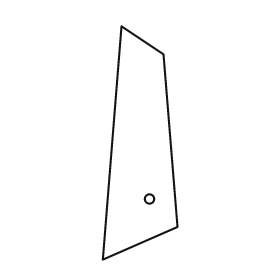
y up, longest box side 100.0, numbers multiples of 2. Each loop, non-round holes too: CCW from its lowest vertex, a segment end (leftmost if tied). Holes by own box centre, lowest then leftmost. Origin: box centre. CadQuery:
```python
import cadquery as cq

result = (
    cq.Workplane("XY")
    .moveTo(-16.0, -50.0)
    .lineTo(16.0, -36.0)
    .lineTo(10.0, 38.0)
    .lineTo(-8.0, 50.0)
    .close()
    .moveTo(4.0, -24.0)
    .circle(2.0)
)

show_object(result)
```